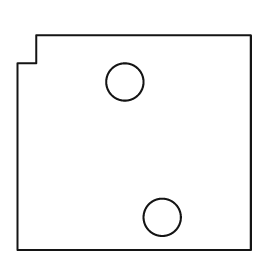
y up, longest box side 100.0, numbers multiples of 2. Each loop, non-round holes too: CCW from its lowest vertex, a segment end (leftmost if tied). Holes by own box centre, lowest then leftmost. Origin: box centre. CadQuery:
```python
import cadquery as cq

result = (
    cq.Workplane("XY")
    .moveTo(-50.0, -46.0)
    .lineTo(50.0, -46.0)
    .lineTo(50.0, 46.0)
    .lineTo(-42.0, 46.0)
    .lineTo(-42.0, 34.0)
    .lineTo(-50.0, 34.0)
    .close()
    .moveTo(12.0, -32.0)
    .circle(8.0)
    .moveTo(-4.0, 26.0)
    .circle(8.0)
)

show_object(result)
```